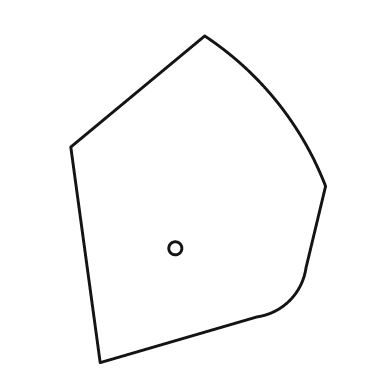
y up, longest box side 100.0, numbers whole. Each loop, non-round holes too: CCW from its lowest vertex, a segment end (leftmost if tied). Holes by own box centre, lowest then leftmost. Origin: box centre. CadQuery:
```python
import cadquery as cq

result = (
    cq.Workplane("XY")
    .moveTo(-30.0, -50.0)
    .lineTo(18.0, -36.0)
    .threePointArc((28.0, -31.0), (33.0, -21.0))
    .lineTo(39.0, 4.0)
    .threePointArc((24.0, 30.0), (2.0, 50.0))
    .lineTo(-39.0, 16.0)
    .close()
    .moveTo(-7.0, -15.0)
    .circle(2.0)
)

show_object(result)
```